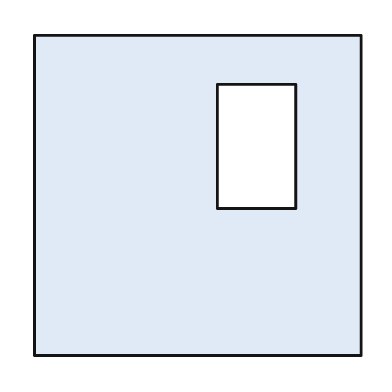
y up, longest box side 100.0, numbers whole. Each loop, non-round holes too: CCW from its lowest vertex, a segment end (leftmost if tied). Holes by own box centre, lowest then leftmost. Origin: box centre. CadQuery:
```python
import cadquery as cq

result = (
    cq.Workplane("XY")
    .moveTo(-50.0, -49.0)
    .lineTo(50.0, -49.0)
    .lineTo(50.0, 49.0)
    .lineTo(-50.0, 49.0)
    .close()
    .moveTo(6.0, -4.0)
    .lineTo(30.0, -4.0)
    .lineTo(30.0, 34.0)
    .lineTo(6.0, 34.0)
    .close()
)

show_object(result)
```